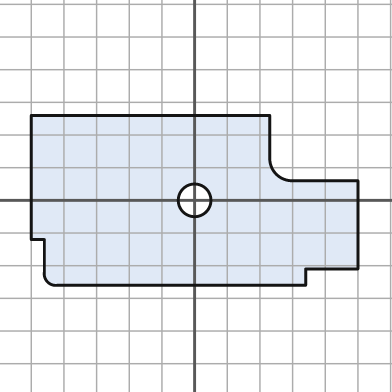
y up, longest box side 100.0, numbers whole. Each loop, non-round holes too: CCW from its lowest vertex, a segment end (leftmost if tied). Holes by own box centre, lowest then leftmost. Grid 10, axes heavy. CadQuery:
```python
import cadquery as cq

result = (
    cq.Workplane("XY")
    .moveTo(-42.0, -26.0)
    .lineTo(34.0, -26.0)
    .lineTo(34.0, -21.0)
    .lineTo(50.0, -21.0)
    .lineTo(50.0, 6.0)
    .lineTo(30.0, 6.0)
    .threePointArc((25.0, 8.0), (23.0, 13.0))
    .lineTo(23.0, 26.0)
    .lineTo(-50.0, 26.0)
    .lineTo(-50.0, -12.0)
    .lineTo(-46.0, -12.0)
    .lineTo(-46.0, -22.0)
    .threePointArc((-45.0, -25.0), (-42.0, -26.0))
    .close()
    .moveTo(0.0, 0.0)
    .circle(5.0)
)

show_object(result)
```